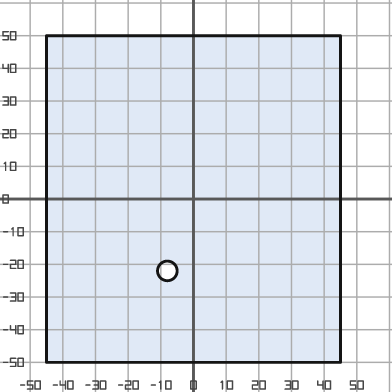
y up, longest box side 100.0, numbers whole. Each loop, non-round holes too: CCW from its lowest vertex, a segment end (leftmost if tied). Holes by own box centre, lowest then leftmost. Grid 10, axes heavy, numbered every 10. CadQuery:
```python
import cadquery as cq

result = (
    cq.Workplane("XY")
    .moveTo(-45.0, -50.0)
    .lineTo(45.0, -50.0)
    .lineTo(45.0, 50.0)
    .lineTo(-45.0, 50.0)
    .close()
    .moveTo(-8.0, -22.0)
    .circle(3.0)
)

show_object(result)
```